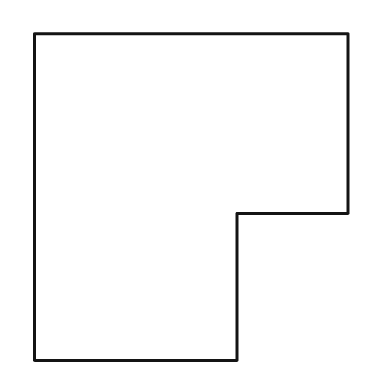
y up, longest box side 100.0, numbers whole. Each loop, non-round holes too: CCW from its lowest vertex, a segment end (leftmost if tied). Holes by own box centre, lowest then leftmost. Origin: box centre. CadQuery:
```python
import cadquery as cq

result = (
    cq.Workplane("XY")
    .moveTo(-48.0, -50.0)
    .lineTo(14.0, -50.0)
    .lineTo(14.0, -5.0)
    .lineTo(48.0, -5.0)
    .lineTo(48.0, 50.0)
    .lineTo(-48.0, 50.0)
    .close()
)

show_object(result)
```